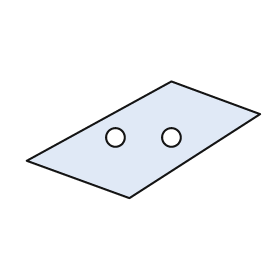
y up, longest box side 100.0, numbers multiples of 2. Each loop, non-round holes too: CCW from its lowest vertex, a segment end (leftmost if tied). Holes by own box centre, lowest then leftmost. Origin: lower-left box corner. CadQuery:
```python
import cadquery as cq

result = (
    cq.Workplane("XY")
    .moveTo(44.0, 0.0)
    .lineTo(100.0, 36.0)
    .lineTo(62.0, 50.0)
    .lineTo(0.0, 16.0)
    .close()
    .moveTo(38.0, 26.0)
    .circle(4.0)
    .moveTo(62.0, 26.0)
    .circle(4.0)
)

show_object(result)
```